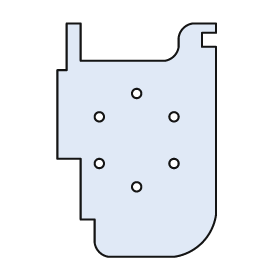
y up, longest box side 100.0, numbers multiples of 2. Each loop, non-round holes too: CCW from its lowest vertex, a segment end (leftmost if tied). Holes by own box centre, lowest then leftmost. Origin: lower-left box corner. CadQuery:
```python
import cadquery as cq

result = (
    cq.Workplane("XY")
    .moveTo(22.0, 0.0)
    .lineTo(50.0, 0.0)
    .threePointArc((62.0, 6.0), (68.0, 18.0))
    .lineTo(68.0, 90.0)
    .lineTo(62.0, 90.0)
    .lineTo(62.0, 96.0)
    .lineTo(68.0, 96.0)
    .lineTo(68.0, 100.0)
    .lineTo(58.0, 100.0)
    .threePointArc((54.0, 98.0), (52.0, 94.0))
    .lineTo(52.0, 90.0)
    .threePointArc((50.0, 86.0), (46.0, 84.0))
    .lineTo(10.0, 84.0)
    .lineTo(10.0, 100.0)
    .lineTo(4.0, 100.0)
    .lineTo(4.0, 80.0)
    .lineTo(0.0, 80.0)
    .lineTo(0.0, 42.0)
    .lineTo(10.0, 42.0)
    .lineTo(10.0, 16.0)
    .lineTo(16.0, 16.0)
    .lineTo(16.0, 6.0)
    .threePointArc((18.0, 2.0), (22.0, 0.0))
    .close()
    .moveTo(34.0, 30.0)
    .circle(2.0)
    .moveTo(18.0, 40.0)
    .circle(2.0)
    .moveTo(50.0, 40.0)
    .circle(2.0)
    .moveTo(18.0, 60.0)
    .circle(2.0)
    .moveTo(50.0, 60.0)
    .circle(2.0)
    .moveTo(34.0, 70.0)
    .circle(2.0)
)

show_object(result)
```